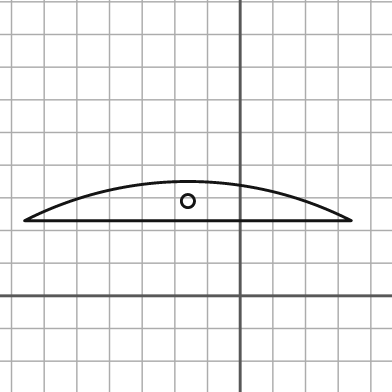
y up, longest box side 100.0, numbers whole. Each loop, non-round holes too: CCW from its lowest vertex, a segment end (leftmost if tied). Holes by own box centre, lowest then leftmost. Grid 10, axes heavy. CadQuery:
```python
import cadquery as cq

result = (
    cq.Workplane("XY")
    .moveTo(-66.0, 23.0)
    .lineTo(34.0, 23.0)
    .threePointArc((-16.0, 35.0), (-66.0, 23.0))
    .close()
    .moveTo(-16.0, 29.0)
    .circle(2.0)
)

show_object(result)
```